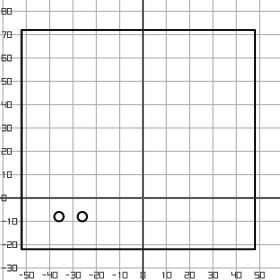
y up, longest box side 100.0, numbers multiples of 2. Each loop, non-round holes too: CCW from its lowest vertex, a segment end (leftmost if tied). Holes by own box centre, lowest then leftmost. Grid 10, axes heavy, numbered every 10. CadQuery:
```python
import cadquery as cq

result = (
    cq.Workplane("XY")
    .moveTo(-52.0, -22.0)
    .lineTo(48.0, -22.0)
    .lineTo(48.0, 72.0)
    .lineTo(-52.0, 72.0)
    .close()
    .moveTo(-36.0, -8.0)
    .circle(2.0)
    .moveTo(-26.0, -8.0)
    .circle(2.0)
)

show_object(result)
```